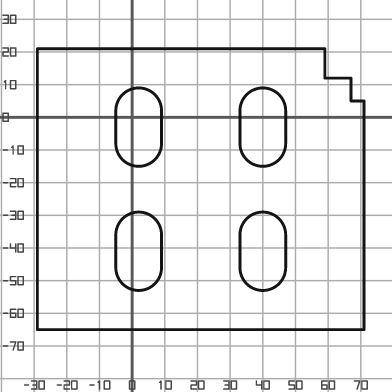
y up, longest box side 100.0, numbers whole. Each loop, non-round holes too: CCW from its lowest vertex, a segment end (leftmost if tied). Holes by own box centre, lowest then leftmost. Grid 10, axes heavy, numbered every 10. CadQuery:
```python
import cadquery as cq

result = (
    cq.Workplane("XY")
    .moveTo(-29.0, -65.0)
    .lineTo(71.0, -65.0)
    .lineTo(71.0, 5.0)
    .lineTo(67.0, 5.0)
    .lineTo(67.0, 12.0)
    .lineTo(59.0, 12.0)
    .lineTo(59.0, 21.0)
    .lineTo(-29.0, 21.0)
    .close()
    .moveTo(-5.0, -46.0)
    .threePointArc((2.0, -53.0), (9.0, -46.0))
    .lineTo(9.0, -36.0)
    .threePointArc((2.0, -29.0), (-5.0, -36.0))
    .close()
    .moveTo(33.0, -46.0)
    .threePointArc((40.0, -53.0), (47.0, -46.0))
    .lineTo(47.0, -36.0)
    .threePointArc((40.0, -29.0), (33.0, -36.0))
    .close()
    .moveTo(-5.0, -8.0)
    .threePointArc((2.0, -15.0), (9.0, -8.0))
    .lineTo(9.0, 2.0)
    .threePointArc((2.0, 9.0), (-5.0, 2.0))
    .close()
    .moveTo(33.0, -8.0)
    .threePointArc((40.0, -15.0), (47.0, -8.0))
    .lineTo(47.0, 2.0)
    .threePointArc((40.0, 9.0), (33.0, 2.0))
    .close()
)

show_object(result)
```